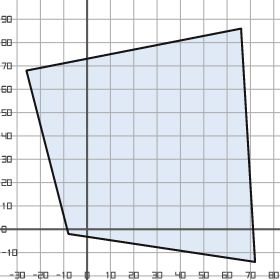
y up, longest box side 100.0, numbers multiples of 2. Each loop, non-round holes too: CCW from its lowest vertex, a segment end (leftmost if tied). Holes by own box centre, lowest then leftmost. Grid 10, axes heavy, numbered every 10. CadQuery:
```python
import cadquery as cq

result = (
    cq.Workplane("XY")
    .moveTo(72.0, -14.0)
    .lineTo(66.0, 86.0)
    .lineTo(-26.0, 68.0)
    .lineTo(-8.0, -2.0)
    .close()
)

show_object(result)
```